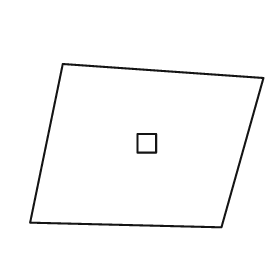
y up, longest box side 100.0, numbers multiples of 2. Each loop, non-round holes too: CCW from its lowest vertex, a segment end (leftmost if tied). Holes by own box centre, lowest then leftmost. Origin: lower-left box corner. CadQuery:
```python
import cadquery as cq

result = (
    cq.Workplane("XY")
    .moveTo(82.0, 0.0)
    .lineTo(100.0, 64.0)
    .lineTo(14.0, 70.0)
    .lineTo(0.0, 2.0)
    .close()
    .moveTo(46.0, 32.0)
    .lineTo(54.0, 32.0)
    .lineTo(54.0, 40.0)
    .lineTo(46.0, 40.0)
    .close()
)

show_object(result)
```